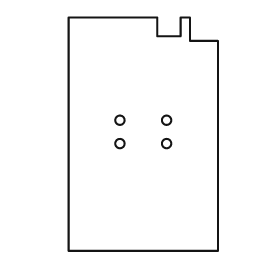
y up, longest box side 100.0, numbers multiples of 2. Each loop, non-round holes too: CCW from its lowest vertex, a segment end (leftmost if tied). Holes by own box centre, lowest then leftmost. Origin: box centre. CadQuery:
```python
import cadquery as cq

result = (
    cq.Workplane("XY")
    .moveTo(-32.0, -50.0)
    .lineTo(32.0, -50.0)
    .lineTo(32.0, 40.0)
    .lineTo(20.0, 40.0)
    .lineTo(20.0, 50.0)
    .lineTo(16.0, 50.0)
    .lineTo(16.0, 42.0)
    .lineTo(6.0, 42.0)
    .lineTo(6.0, 50.0)
    .lineTo(-32.0, 50.0)
    .close()
    .moveTo(-10.0, -4.0)
    .circle(2.0)
    .moveTo(10.0, -4.0)
    .circle(2.0)
    .moveTo(-10.0, 6.0)
    .circle(2.0)
    .moveTo(10.0, 6.0)
    .circle(2.0)
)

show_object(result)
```